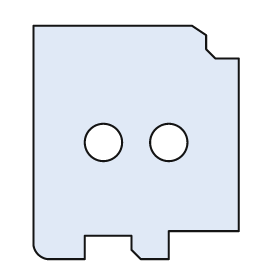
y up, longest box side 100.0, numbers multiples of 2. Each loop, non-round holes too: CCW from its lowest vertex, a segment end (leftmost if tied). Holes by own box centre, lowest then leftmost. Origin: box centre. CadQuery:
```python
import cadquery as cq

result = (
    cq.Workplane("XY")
    .moveTo(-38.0, -50.0)
    .lineTo(-22.0, -50.0)
    .lineTo(-22.0, -40.0)
    .lineTo(-2.0, -40.0)
    .lineTo(-2.0, -46.0)
    .lineTo(2.0, -50.0)
    .lineTo(14.0, -50.0)
    .lineTo(14.0, -38.0)
    .lineTo(44.0, -38.0)
    .lineTo(44.0, 36.0)
    .lineTo(34.0, 36.0)
    .lineTo(30.0, 40.0)
    .lineTo(30.0, 46.0)
    .lineTo(24.0, 50.0)
    .lineTo(-44.0, 50.0)
    .lineTo(-44.0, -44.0)
    .threePointArc((-42.0, -48.0), (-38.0, -50.0))
    .close()
    .moveTo(-14.0, 0.0)
    .circle(8.0)
    .moveTo(14.0, 0.0)
    .circle(8.0)
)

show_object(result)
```